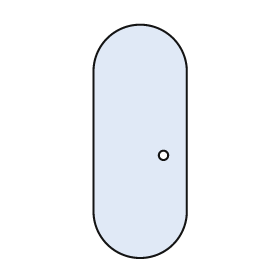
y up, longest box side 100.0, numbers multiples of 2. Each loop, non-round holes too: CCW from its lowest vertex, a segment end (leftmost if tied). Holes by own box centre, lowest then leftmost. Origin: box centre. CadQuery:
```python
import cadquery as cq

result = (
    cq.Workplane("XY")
    .moveTo(-20.0, -30.0)
    .threePointArc((0.0, -50.0), (20.0, -30.0))
    .lineTo(20.0, 30.0)
    .threePointArc((0.0, 50.0), (-20.0, 30.0))
    .close()
    .moveTo(10.0, -6.0)
    .circle(2.0)
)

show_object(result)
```